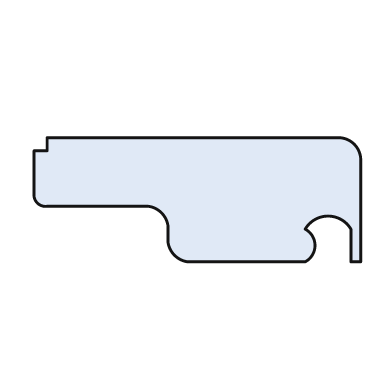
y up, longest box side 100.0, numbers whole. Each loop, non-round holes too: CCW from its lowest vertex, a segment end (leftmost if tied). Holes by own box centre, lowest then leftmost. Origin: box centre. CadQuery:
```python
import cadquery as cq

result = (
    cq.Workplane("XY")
    .moveTo(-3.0, -19.0)
    .lineTo(33.0, -19.0)
    .threePointArc((36.0, -14.0), (33.0, -9.0))
    .threePointArc((40.0, -5.0), (47.0, -9.0))
    .lineTo(47.0, -19.0)
    .lineTo(50.0, -19.0)
    .lineTo(50.0, 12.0)
    .threePointArc((48.0, 17.0), (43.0, 19.0))
    .lineTo(-46.0, 19.0)
    .lineTo(-46.0, 15.0)
    .lineTo(-50.0, 15.0)
    .lineTo(-50.0, 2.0)
    .threePointArc((-49.0, -1.0), (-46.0, -2.0))
    .lineTo(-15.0, -2.0)
    .threePointArc((-11.0, -4.0), (-9.0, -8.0))
    .lineTo(-9.0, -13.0)
    .threePointArc((-7.0, -17.0), (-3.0, -19.0))
    .close()
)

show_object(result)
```